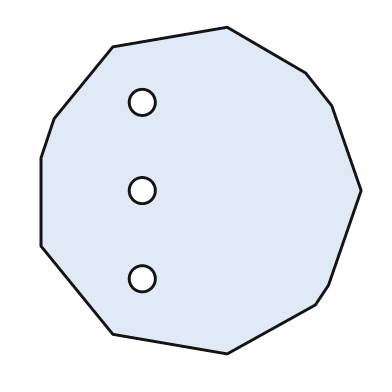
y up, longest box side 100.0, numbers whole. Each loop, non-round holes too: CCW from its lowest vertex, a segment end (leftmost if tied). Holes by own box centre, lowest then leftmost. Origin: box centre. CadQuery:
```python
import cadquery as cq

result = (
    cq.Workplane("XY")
    .moveTo(8.0, -50.0)
    .lineTo(35.0, -35.0)
    .lineTo(39.0, -29.0)
    .lineTo(49.0, 0.0)
    .lineTo(40.0, 26.0)
    .lineTo(32.0, 36.0)
    .lineTo(8.0, 50.0)
    .lineTo(-27.0, 44.0)
    .lineTo(-45.0, 22.0)
    .lineTo(-49.0, 10.0)
    .lineTo(-49.0, -17.0)
    .lineTo(-27.0, -44.0)
    .close()
    .moveTo(-18.0, -27.0)
    .circle(4.0)
    .moveTo(-18.0, 0.0)
    .circle(4.0)
    .moveTo(-18.0, 27.0)
    .circle(4.0)
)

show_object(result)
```